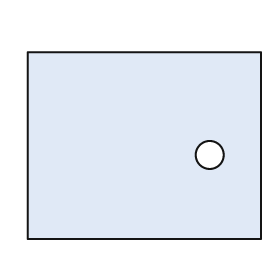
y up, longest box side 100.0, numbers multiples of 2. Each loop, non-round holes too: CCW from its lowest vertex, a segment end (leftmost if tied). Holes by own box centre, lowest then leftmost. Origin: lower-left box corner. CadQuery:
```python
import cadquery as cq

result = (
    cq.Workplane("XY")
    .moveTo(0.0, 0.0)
    .lineTo(100.0, 0.0)
    .lineTo(100.0, 80.0)
    .lineTo(0.0, 80.0)
    .close()
    .moveTo(78.0, 36.0)
    .circle(6.0)
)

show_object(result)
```